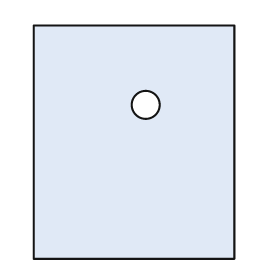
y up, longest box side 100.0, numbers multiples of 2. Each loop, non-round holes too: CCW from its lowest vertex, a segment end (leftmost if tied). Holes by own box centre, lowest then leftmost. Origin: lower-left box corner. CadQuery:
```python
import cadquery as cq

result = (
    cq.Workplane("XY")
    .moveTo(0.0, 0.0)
    .lineTo(86.0, 0.0)
    .lineTo(86.0, 100.0)
    .lineTo(0.0, 100.0)
    .close()
    .moveTo(48.0, 66.0)
    .circle(6.0)
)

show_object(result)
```